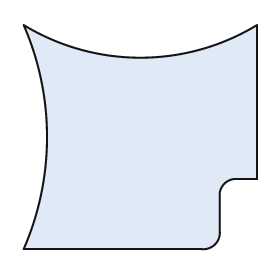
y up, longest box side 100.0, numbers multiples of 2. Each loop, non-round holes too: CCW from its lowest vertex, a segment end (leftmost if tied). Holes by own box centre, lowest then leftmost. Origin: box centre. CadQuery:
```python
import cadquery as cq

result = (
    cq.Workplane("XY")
    .moveTo(-50.0, -48.0)
    .lineTo(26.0, -48.0)
    .threePointArc((32.0, -46.0), (34.0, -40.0))
    .lineTo(34.0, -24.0)
    .threePointArc((36.0, -20.0), (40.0, -18.0))
    .lineTo(50.0, -18.0)
    .lineTo(50.0, 48.0)
    .threePointArc((0.0, 34.0), (-50.0, 48.0))
    .threePointArc((-40.0, 0.0), (-50.0, -48.0))
    .close()
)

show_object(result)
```